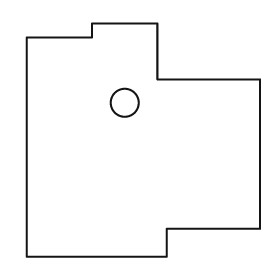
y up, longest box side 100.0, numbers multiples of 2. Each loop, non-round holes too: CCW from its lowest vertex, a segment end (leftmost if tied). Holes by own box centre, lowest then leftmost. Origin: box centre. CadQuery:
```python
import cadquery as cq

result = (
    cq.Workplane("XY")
    .moveTo(-50.0, -50.0)
    .lineTo(10.0, -50.0)
    .lineTo(10.0, -38.0)
    .lineTo(50.0, -38.0)
    .lineTo(50.0, 26.0)
    .lineTo(6.0, 26.0)
    .lineTo(6.0, 50.0)
    .lineTo(-22.0, 50.0)
    .lineTo(-22.0, 44.0)
    .lineTo(-50.0, 44.0)
    .close()
    .moveTo(-8.0, 16.0)
    .circle(6.0)
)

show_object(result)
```